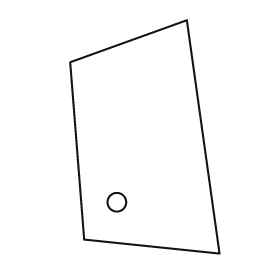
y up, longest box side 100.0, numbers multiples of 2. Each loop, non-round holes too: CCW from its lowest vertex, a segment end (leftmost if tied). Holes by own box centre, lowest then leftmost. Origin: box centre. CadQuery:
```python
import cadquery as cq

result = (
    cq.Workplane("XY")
    .moveTo(32.0, -50.0)
    .lineTo(18.0, 50.0)
    .lineTo(-32.0, 32.0)
    .lineTo(-26.0, -44.0)
    .close()
    .moveTo(-12.0, -28.0)
    .circle(4.0)
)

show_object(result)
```